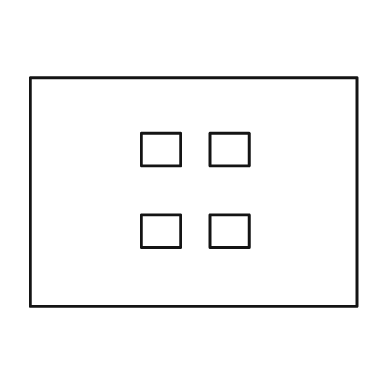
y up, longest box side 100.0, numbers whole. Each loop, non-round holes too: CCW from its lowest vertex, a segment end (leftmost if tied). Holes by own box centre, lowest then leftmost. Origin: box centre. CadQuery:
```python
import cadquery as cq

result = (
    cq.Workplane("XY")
    .moveTo(-50.0, -35.0)
    .lineTo(50.0, -35.0)
    .lineTo(50.0, 35.0)
    .lineTo(-50.0, 35.0)
    .close()
    .moveTo(-16.0, -17.0)
    .lineTo(-4.0, -17.0)
    .lineTo(-4.0, -7.0)
    .lineTo(-16.0, -7.0)
    .close()
    .moveTo(5.0, -17.0)
    .lineTo(17.0, -17.0)
    .lineTo(17.0, -7.0)
    .lineTo(5.0, -7.0)
    .close()
    .moveTo(-16.0, 8.0)
    .lineTo(-4.0, 8.0)
    .lineTo(-4.0, 18.0)
    .lineTo(-16.0, 18.0)
    .close()
    .moveTo(5.0, 8.0)
    .lineTo(17.0, 8.0)
    .lineTo(17.0, 18.0)
    .lineTo(5.0, 18.0)
    .close()
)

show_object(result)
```